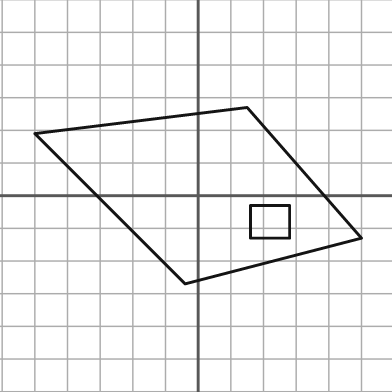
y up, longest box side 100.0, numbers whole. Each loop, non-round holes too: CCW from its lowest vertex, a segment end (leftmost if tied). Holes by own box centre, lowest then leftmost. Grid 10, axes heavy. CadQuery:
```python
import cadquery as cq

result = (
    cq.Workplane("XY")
    .moveTo(-4.0, -27.0)
    .lineTo(50.0, -13.0)
    .lineTo(15.0, 27.0)
    .lineTo(-50.0, 19.0)
    .close()
    .moveTo(16.0, -13.0)
    .lineTo(28.0, -13.0)
    .lineTo(28.0, -3.0)
    .lineTo(16.0, -3.0)
    .close()
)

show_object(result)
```